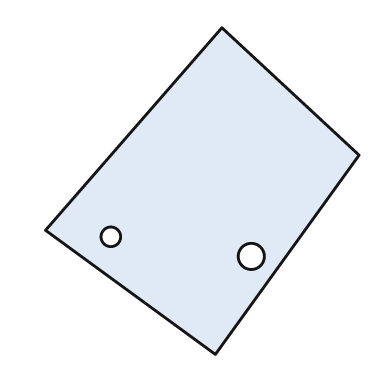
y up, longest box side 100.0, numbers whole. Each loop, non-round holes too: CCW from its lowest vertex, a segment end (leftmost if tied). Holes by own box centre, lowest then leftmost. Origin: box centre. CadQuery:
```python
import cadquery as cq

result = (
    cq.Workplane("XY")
    .moveTo(4.0, -50.0)
    .lineTo(48.0, 11.0)
    .lineTo(6.0, 50.0)
    .lineTo(-48.0, -12.0)
    .close()
    .moveTo(15.0, -20.0)
    .circle(4.0)
    .moveTo(-28.0, -14.0)
    .circle(3.0)
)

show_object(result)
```